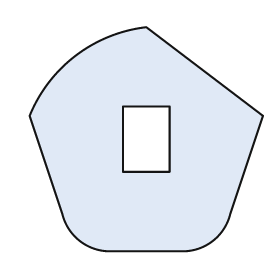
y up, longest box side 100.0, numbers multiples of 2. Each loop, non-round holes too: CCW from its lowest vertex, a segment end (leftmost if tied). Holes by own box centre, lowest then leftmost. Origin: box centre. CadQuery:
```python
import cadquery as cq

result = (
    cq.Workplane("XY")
    .moveTo(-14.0, -48.0)
    .lineTo(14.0, -48.0)
    .threePointArc((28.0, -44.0), (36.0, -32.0))
    .lineTo(50.0, 10.0)
    .lineTo(0.0, 48.0)
    .threePointArc((-30.0, 36.0), (-50.0, 10.0))
    .lineTo(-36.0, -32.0)
    .threePointArc((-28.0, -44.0), (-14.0, -48.0))
    .close()
    .moveTo(-10.0, -14.0)
    .lineTo(10.0, -14.0)
    .lineTo(10.0, 14.0)
    .lineTo(-10.0, 14.0)
    .close()
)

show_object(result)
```